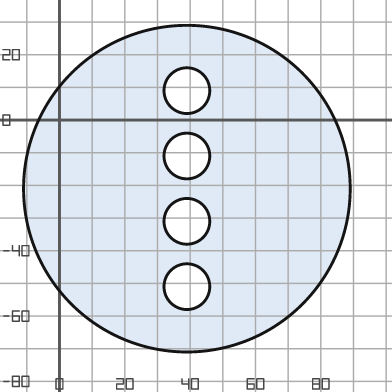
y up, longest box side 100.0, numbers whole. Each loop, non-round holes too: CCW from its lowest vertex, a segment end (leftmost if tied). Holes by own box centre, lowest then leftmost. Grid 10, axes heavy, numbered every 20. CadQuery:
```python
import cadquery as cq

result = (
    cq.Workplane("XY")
    .moveTo(39.0, -21.0)
    .circle(50.0)
    .moveTo(39.0, -51.0)
    .circle(7.0)
    .moveTo(39.0, -31.0)
    .circle(7.0)
    .moveTo(39.0, -11.0)
    .circle(7.0)
    .moveTo(39.0, 9.0)
    .circle(7.0)
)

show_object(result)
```